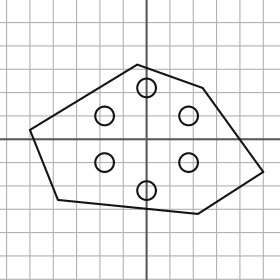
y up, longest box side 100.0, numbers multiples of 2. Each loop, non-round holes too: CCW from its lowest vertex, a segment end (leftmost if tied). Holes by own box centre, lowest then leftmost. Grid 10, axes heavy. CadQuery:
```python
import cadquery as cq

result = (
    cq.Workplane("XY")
    .moveTo(22.0, -32.0)
    .lineTo(50.0, -14.0)
    .lineTo(24.0, 22.0)
    .lineTo(-4.0, 32.0)
    .lineTo(-50.0, 4.0)
    .lineTo(-38.0, -26.0)
    .close()
    .moveTo(0.0, -22.0)
    .circle(4.0)
    .moveTo(-18.0, -10.0)
    .circle(4.0)
    .moveTo(18.0, -10.0)
    .circle(4.0)
    .moveTo(-18.0, 10.0)
    .circle(4.0)
    .moveTo(18.0, 10.0)
    .circle(4.0)
    .moveTo(0.0, 22.0)
    .circle(4.0)
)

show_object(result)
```